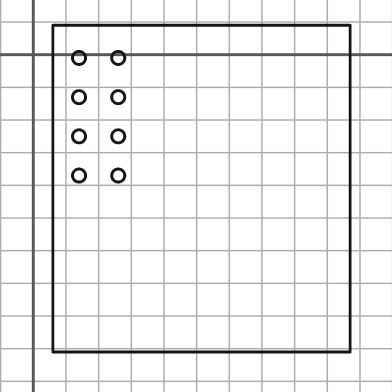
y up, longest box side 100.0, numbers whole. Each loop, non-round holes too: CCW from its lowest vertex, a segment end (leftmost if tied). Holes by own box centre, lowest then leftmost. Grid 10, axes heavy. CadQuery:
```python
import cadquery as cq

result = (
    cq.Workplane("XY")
    .moveTo(6.0, -91.0)
    .lineTo(97.0, -91.0)
    .lineTo(97.0, 9.0)
    .lineTo(6.0, 9.0)
    .close()
    .moveTo(14.0, -37.0)
    .circle(2.0)
    .moveTo(26.0, -37.0)
    .circle(2.0)
    .moveTo(14.0, -25.0)
    .circle(2.0)
    .moveTo(26.0, -25.0)
    .circle(2.0)
    .moveTo(14.0, -13.0)
    .circle(2.0)
    .moveTo(26.0, -13.0)
    .circle(2.0)
    .moveTo(14.0, -1.0)
    .circle(2.0)
    .moveTo(26.0, -1.0)
    .circle(2.0)
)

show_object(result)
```